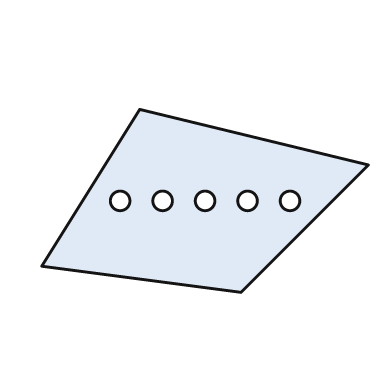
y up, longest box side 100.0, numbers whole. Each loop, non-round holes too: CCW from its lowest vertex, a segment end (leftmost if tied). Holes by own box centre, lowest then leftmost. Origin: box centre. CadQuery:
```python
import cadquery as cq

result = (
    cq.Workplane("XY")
    .moveTo(11.0, -28.0)
    .lineTo(50.0, 11.0)
    .lineTo(-20.0, 28.0)
    .lineTo(-50.0, -20.0)
    .close()
    .moveTo(-26.0, 0.0)
    .circle(3.0)
    .moveTo(-13.0, 0.0)
    .circle(3.0)
    .moveTo(0.0, 0.0)
    .circle(3.0)
    .moveTo(13.0, 0.0)
    .circle(3.0)
    .moveTo(26.0, 0.0)
    .circle(3.0)
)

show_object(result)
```